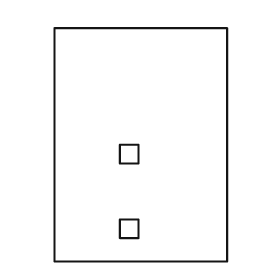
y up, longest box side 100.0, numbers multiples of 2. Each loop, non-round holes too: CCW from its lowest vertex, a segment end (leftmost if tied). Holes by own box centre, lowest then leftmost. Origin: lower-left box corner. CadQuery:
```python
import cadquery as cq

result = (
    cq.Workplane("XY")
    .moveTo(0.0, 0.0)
    .lineTo(74.0, 0.0)
    .lineTo(74.0, 100.0)
    .lineTo(0.0, 100.0)
    .close()
    .moveTo(28.0, 10.0)
    .lineTo(36.0, 10.0)
    .lineTo(36.0, 18.0)
    .lineTo(28.0, 18.0)
    .close()
    .moveTo(28.0, 42.0)
    .lineTo(36.0, 42.0)
    .lineTo(36.0, 50.0)
    .lineTo(28.0, 50.0)
    .close()
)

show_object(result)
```